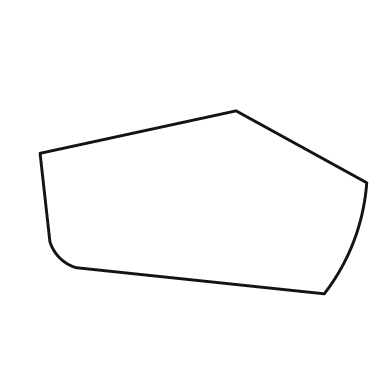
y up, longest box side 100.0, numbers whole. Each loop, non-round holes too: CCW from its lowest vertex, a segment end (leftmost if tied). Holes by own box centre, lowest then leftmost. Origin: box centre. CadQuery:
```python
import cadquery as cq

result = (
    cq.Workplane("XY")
    .moveTo(37.0, -28.0)
    .threePointArc((46.0, -12.0), (50.0, 6.0))
    .lineTo(10.0, 28.0)
    .lineTo(-50.0, 15.0)
    .lineTo(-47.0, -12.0)
    .threePointArc((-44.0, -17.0), (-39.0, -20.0))
    .close()
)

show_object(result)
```